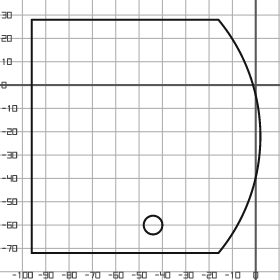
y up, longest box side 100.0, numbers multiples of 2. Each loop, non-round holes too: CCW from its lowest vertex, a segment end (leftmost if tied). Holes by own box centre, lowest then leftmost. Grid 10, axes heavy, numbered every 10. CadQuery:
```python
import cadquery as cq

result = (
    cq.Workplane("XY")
    .moveTo(-96.0, -72.0)
    .lineTo(-16.0, -72.0)
    .threePointArc((2.0, -22.0), (-16.0, 28.0))
    .lineTo(-96.0, 28.0)
    .close()
    .moveTo(-44.0, -60.0)
    .circle(4.0)
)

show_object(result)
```